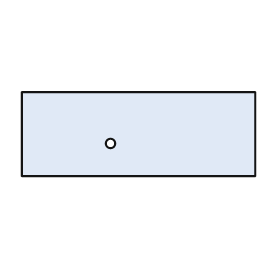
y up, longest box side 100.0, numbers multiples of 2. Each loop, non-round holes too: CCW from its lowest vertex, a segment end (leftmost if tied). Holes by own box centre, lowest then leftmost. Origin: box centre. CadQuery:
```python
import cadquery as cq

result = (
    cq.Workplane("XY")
    .moveTo(-50.0, -18.0)
    .lineTo(50.0, -18.0)
    .lineTo(50.0, 18.0)
    .lineTo(-50.0, 18.0)
    .close()
    .moveTo(-12.0, -4.0)
    .circle(2.0)
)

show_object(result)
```